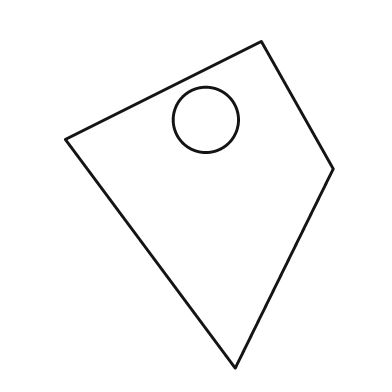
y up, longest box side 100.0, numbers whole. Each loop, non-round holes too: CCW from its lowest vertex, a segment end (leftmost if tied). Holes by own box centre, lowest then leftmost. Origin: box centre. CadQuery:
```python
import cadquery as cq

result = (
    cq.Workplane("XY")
    .moveTo(11.0, -50.0)
    .lineTo(41.0, 11.0)
    .lineTo(19.0, 50.0)
    .lineTo(-41.0, 20.0)
    .close()
    .moveTo(2.0, 26.0)
    .circle(10.0)
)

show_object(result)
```